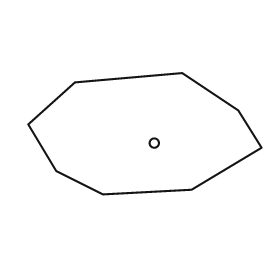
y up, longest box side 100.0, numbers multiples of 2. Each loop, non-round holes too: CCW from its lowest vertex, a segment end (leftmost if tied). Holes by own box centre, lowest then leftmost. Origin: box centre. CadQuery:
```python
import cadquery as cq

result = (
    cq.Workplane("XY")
    .moveTo(-18.0, -26.0)
    .lineTo(20.0, -24.0)
    .lineTo(50.0, -6.0)
    .lineTo(40.0, 10.0)
    .lineTo(16.0, 26.0)
    .lineTo(-30.0, 22.0)
    .lineTo(-50.0, 4.0)
    .lineTo(-38.0, -16.0)
    .close()
    .moveTo(4.0, -4.0)
    .circle(2.0)
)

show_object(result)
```